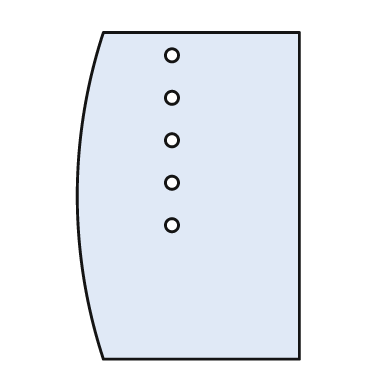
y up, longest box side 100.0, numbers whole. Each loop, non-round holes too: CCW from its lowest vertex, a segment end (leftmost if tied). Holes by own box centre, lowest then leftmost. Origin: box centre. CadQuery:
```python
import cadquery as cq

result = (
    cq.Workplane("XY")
    .moveTo(-26.0, -50.0)
    .lineTo(34.0, -50.0)
    .lineTo(34.0, 50.0)
    .lineTo(-26.0, 50.0)
    .threePointArc((-34.0, 0.0), (-26.0, -50.0))
    .close()
    .moveTo(-5.0, -9.0)
    .circle(2.0)
    .moveTo(-5.0, 4.0)
    .circle(2.0)
    .moveTo(-5.0, 17.0)
    .circle(2.0)
    .moveTo(-5.0, 30.0)
    .circle(2.0)
    .moveTo(-5.0, 43.0)
    .circle(2.0)
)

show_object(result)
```